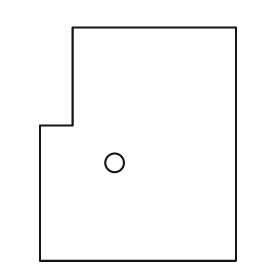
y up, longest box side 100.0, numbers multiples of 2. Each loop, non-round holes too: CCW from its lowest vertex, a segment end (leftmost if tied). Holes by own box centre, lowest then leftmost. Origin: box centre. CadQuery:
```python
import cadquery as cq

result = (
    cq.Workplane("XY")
    .moveTo(-42.0, -50.0)
    .lineTo(42.0, -50.0)
    .lineTo(42.0, 50.0)
    .lineTo(-28.0, 50.0)
    .lineTo(-28.0, 8.0)
    .lineTo(-42.0, 8.0)
    .close()
    .moveTo(-10.0, -8.0)
    .circle(4.0)
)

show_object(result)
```